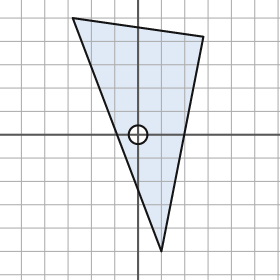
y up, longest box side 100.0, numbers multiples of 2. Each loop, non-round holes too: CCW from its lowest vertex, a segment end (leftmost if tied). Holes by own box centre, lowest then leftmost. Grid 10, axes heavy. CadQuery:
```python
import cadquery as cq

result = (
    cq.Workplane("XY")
    .moveTo(10.0, -50.0)
    .lineTo(28.0, 42.0)
    .lineTo(-28.0, 50.0)
    .close()
    .moveTo(0.0, 0.0)
    .circle(4.0)
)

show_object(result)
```